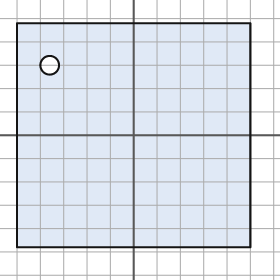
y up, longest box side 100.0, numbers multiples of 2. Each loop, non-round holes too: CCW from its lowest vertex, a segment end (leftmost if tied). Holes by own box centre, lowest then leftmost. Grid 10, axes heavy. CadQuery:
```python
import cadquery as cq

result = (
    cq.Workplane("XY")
    .moveTo(-50.0, -48.0)
    .lineTo(50.0, -48.0)
    .lineTo(50.0, 48.0)
    .lineTo(-50.0, 48.0)
    .close()
    .moveTo(-36.0, 30.0)
    .circle(4.0)
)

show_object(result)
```